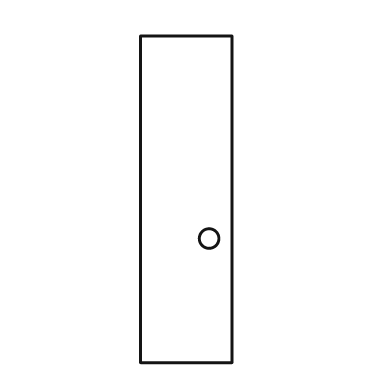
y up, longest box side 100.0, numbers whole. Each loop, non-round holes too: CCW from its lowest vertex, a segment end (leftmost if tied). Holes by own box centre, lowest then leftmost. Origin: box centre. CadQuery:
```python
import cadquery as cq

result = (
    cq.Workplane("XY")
    .moveTo(-14.0, -50.0)
    .lineTo(14.0, -50.0)
    .lineTo(14.0, 50.0)
    .lineTo(-14.0, 50.0)
    .close()
    .moveTo(7.0, -12.0)
    .circle(3.0)
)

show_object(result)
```